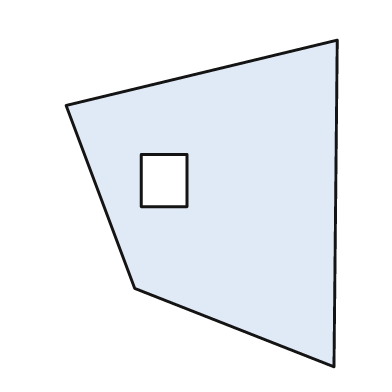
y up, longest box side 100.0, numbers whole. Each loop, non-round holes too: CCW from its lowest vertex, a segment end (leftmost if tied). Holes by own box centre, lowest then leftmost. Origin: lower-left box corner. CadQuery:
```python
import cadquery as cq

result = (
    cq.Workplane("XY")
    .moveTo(82.0, 0.0)
    .lineTo(83.0, 100.0)
    .lineTo(0.0, 80.0)
    .lineTo(21.0, 24.0)
    .close()
    .moveTo(23.0, 49.0)
    .lineTo(37.0, 49.0)
    .lineTo(37.0, 65.0)
    .lineTo(23.0, 65.0)
    .close()
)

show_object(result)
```